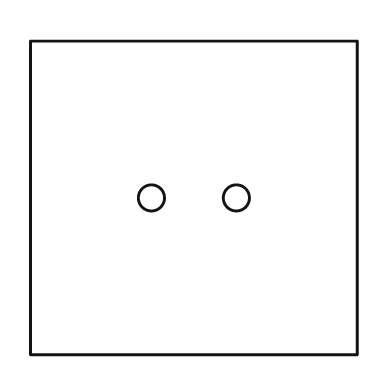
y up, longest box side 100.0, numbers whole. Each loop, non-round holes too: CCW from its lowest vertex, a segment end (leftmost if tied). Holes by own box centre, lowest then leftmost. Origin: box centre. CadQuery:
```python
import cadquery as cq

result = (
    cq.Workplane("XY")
    .moveTo(-50.0, -48.0)
    .lineTo(50.0, -48.0)
    .lineTo(50.0, 48.0)
    .lineTo(-50.0, 48.0)
    .close()
    .moveTo(-13.0, 0.0)
    .circle(4.0)
    .moveTo(13.0, 0.0)
    .circle(4.0)
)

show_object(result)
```